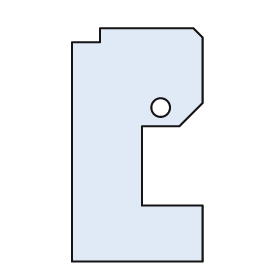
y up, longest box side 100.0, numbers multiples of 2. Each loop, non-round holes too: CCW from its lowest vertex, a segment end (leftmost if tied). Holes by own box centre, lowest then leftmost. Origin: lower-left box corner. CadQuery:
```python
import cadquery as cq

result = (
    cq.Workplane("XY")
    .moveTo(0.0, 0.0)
    .lineTo(56.0, 0.0)
    .lineTo(56.0, 24.0)
    .lineTo(30.0, 24.0)
    .lineTo(30.0, 58.0)
    .lineTo(46.0, 58.0)
    .lineTo(56.0, 68.0)
    .lineTo(56.0, 96.0)
    .lineTo(52.0, 100.0)
    .lineTo(12.0, 100.0)
    .lineTo(12.0, 94.0)
    .lineTo(0.0, 94.0)
    .close()
    .moveTo(38.0, 66.0)
    .circle(4.0)
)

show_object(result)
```